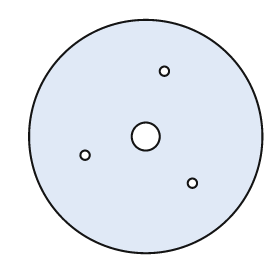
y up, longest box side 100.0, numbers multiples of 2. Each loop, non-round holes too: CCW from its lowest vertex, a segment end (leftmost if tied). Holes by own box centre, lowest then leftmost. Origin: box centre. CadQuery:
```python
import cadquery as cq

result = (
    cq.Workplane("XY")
    .moveTo(0.0, 0.0)
    .circle(50.0)
    .moveTo(20.0, -20.0)
    .circle(2.0)
    .moveTo(-26.0, -8.0)
    .circle(2.0)
    .moveTo(0.0, 0.0)
    .circle(6.0)
    .moveTo(8.0, 28.0)
    .circle(2.0)
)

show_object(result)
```